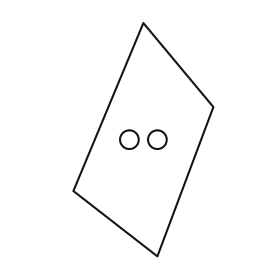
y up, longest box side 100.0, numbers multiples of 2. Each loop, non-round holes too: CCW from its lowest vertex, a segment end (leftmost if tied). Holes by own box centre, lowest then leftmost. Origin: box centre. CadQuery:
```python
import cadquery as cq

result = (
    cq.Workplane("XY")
    .moveTo(6.0, -50.0)
    .lineTo(30.0, 14.0)
    .lineTo(0.0, 50.0)
    .lineTo(-30.0, -22.0)
    .close()
    .moveTo(-6.0, 0.0)
    .circle(4.0)
    .moveTo(6.0, 0.0)
    .circle(4.0)
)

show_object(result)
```